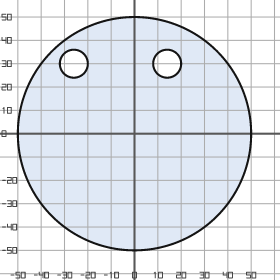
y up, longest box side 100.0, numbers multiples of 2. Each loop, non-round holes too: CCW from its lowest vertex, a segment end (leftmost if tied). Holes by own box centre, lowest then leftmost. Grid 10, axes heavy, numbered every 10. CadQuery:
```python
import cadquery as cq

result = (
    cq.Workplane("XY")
    .moveTo(0.0, 0.0)
    .circle(50.0)
    .moveTo(-26.0, 30.0)
    .circle(6.0)
    .moveTo(14.0, 30.0)
    .circle(6.0)
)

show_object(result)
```